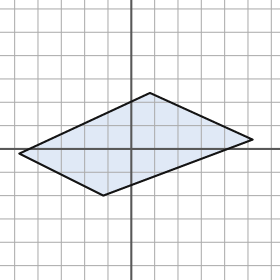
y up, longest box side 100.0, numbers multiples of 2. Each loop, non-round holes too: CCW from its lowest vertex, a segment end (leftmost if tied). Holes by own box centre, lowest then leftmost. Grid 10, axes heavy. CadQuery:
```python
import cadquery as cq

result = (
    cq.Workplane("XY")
    .moveTo(-12.0, -20.0)
    .lineTo(52.0, 4.0)
    .lineTo(8.0, 24.0)
    .lineTo(-48.0, -2.0)
    .close()
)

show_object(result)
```